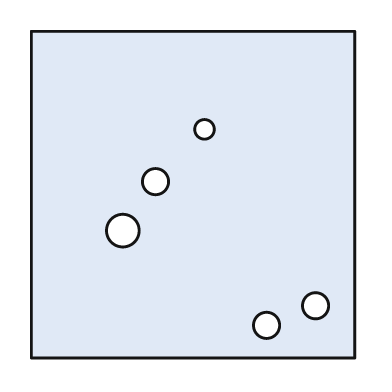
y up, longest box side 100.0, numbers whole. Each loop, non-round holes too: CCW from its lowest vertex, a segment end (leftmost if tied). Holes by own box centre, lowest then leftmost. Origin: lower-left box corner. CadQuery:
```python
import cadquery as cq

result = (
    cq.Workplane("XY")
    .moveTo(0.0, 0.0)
    .lineTo(99.0, 0.0)
    .lineTo(99.0, 100.0)
    .lineTo(0.0, 100.0)
    .close()
    .moveTo(72.0, 10.0)
    .circle(4.0)
    .moveTo(87.0, 16.0)
    .circle(4.0)
    .moveTo(28.0, 39.0)
    .circle(5.0)
    .moveTo(38.0, 54.0)
    .circle(4.0)
    .moveTo(53.0, 70.0)
    .circle(3.0)
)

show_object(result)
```